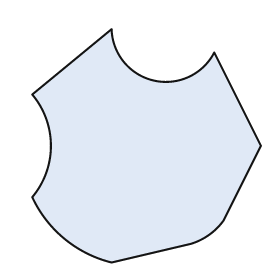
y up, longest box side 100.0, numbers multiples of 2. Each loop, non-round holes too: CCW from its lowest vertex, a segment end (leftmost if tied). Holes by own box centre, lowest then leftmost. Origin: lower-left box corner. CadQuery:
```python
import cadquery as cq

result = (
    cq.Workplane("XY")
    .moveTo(34.0, 0.0)
    .lineTo(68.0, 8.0)
    .threePointArc((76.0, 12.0), (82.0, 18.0))
    .lineTo(98.0, 50.0)
    .lineTo(78.0, 90.0)
    .threePointArc((52.0, 78.0), (34.0, 100.0))
    .lineTo(0.0, 72.0)
    .threePointArc((8.0, 50.0), (0.0, 28.0))
    .threePointArc((14.0, 10.0), (34.0, 0.0))
    .close()
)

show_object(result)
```